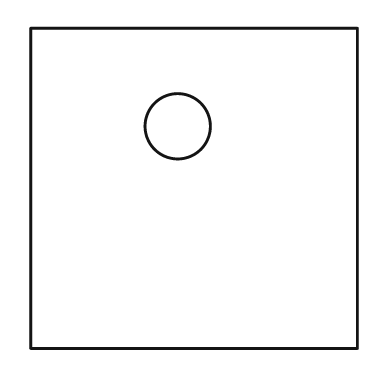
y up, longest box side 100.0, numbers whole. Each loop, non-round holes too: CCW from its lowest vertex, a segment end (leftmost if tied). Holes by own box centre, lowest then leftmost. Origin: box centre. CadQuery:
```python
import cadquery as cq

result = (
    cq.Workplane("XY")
    .moveTo(-50.0, -49.0)
    .lineTo(50.0, -49.0)
    .lineTo(50.0, 49.0)
    .lineTo(-50.0, 49.0)
    .close()
    .moveTo(-5.0, 19.0)
    .circle(10.0)
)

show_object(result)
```